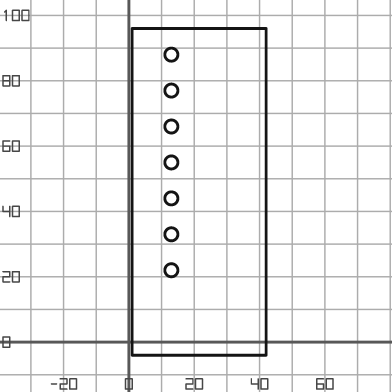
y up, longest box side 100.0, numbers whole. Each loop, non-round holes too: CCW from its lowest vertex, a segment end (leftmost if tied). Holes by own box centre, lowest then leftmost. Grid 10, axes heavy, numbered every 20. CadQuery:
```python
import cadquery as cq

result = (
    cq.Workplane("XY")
    .moveTo(1.0, -4.0)
    .lineTo(42.0, -4.0)
    .lineTo(42.0, 96.0)
    .lineTo(1.0, 96.0)
    .close()
    .moveTo(13.0, 22.0)
    .circle(2.0)
    .moveTo(13.0, 33.0)
    .circle(2.0)
    .moveTo(13.0, 44.0)
    .circle(2.0)
    .moveTo(13.0, 55.0)
    .circle(2.0)
    .moveTo(13.0, 66.0)
    .circle(2.0)
    .moveTo(13.0, 77.0)
    .circle(2.0)
    .moveTo(13.0, 88.0)
    .circle(2.0)
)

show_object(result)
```